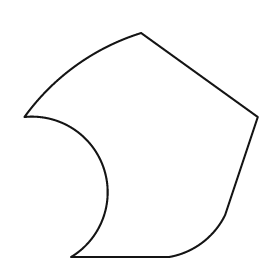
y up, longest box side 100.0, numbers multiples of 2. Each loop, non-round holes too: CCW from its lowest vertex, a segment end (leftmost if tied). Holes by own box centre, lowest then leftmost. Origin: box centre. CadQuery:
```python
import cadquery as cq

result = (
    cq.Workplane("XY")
    .moveTo(-30.0, -48.0)
    .lineTo(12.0, -48.0)
    .threePointArc((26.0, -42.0), (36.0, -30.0))
    .lineTo(50.0, 12.0)
    .lineTo(0.0, 48.0)
    .threePointArc((-28.0, 34.0), (-50.0, 12.0))
    .threePointArc((-16.0, -10.0), (-30.0, -48.0))
    .close()
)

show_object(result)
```